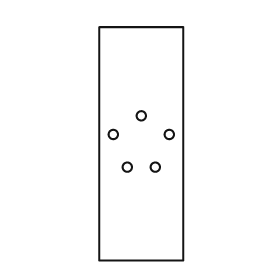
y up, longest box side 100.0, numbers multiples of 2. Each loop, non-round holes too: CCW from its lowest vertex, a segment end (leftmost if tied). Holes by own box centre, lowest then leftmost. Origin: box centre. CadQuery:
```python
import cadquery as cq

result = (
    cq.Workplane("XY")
    .moveTo(-18.0, -50.0)
    .lineTo(18.0, -50.0)
    .lineTo(18.0, 50.0)
    .lineTo(-18.0, 50.0)
    .close()
    .moveTo(-6.0, -10.0)
    .circle(2.0)
    .moveTo(6.0, -10.0)
    .circle(2.0)
    .moveTo(-12.0, 4.0)
    .circle(2.0)
    .moveTo(12.0, 4.0)
    .circle(2.0)
    .moveTo(0.0, 12.0)
    .circle(2.0)
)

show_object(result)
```